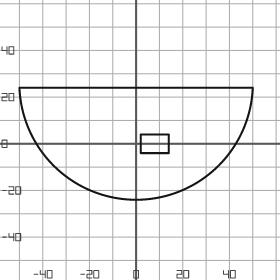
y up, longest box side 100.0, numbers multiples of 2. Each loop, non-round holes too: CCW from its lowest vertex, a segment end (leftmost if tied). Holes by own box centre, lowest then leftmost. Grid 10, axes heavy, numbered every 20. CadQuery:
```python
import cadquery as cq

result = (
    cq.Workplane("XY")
    .moveTo(-50.0, 24.0)
    .threePointArc((0.0, -24.0), (50.0, 24.0))
    .close()
    .moveTo(2.0, -4.0)
    .lineTo(14.0, -4.0)
    .lineTo(14.0, 4.0)
    .lineTo(2.0, 4.0)
    .close()
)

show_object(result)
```